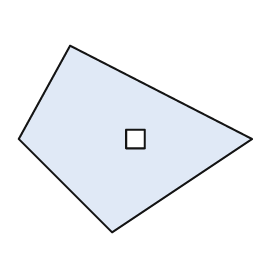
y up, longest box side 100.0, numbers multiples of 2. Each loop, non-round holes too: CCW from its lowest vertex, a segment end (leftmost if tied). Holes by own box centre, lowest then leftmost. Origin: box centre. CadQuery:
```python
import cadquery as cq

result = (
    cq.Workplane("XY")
    .moveTo(-10.0, -40.0)
    .lineTo(50.0, 0.0)
    .lineTo(-28.0, 40.0)
    .lineTo(-50.0, 0.0)
    .close()
    .moveTo(-4.0, -4.0)
    .lineTo(4.0, -4.0)
    .lineTo(4.0, 4.0)
    .lineTo(-4.0, 4.0)
    .close()
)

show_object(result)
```